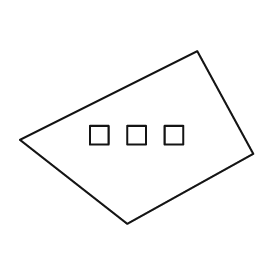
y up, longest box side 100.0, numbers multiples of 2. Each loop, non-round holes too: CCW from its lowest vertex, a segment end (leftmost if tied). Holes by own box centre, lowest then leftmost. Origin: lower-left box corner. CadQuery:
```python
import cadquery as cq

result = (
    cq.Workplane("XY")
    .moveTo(46.0, 0.0)
    .lineTo(100.0, 30.0)
    .lineTo(76.0, 74.0)
    .lineTo(0.0, 36.0)
    .close()
    .moveTo(30.0, 34.0)
    .lineTo(38.0, 34.0)
    .lineTo(38.0, 42.0)
    .lineTo(30.0, 42.0)
    .close()
    .moveTo(46.0, 34.0)
    .lineTo(54.0, 34.0)
    .lineTo(54.0, 42.0)
    .lineTo(46.0, 42.0)
    .close()
    .moveTo(62.0, 34.0)
    .lineTo(70.0, 34.0)
    .lineTo(70.0, 42.0)
    .lineTo(62.0, 42.0)
    .close()
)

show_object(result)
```